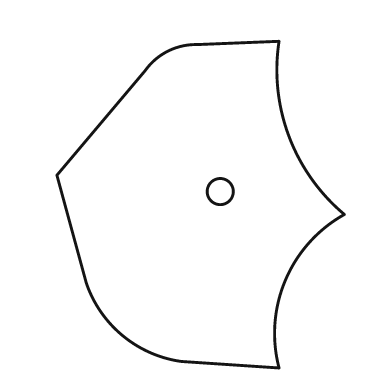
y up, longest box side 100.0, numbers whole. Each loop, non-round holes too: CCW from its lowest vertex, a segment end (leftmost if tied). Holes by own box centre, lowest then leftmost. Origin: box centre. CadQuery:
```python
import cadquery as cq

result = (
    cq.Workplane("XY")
    .moveTo(24.0, -50.0)
    .threePointArc((26.0, -23.0), (44.0, -3.0))
    .threePointArc((27.0, 21.0), (24.0, 50.0))
    .lineTo(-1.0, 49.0)
    .threePointArc((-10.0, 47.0), (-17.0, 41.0))
    .lineTo(-44.0, 9.0)
    .lineTo(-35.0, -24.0)
    .threePointArc((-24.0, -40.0), (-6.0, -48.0))
    .close()
    .moveTo(6.0, 4.0)
    .circle(4.0)
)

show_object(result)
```